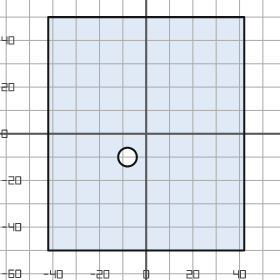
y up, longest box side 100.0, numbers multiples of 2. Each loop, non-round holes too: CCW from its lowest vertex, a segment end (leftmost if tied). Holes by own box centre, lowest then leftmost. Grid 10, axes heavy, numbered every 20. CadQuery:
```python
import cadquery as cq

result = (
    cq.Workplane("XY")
    .moveTo(-42.0, -50.0)
    .lineTo(42.0, -50.0)
    .lineTo(42.0, 50.0)
    .lineTo(-42.0, 50.0)
    .close()
    .moveTo(-8.0, -10.0)
    .circle(4.0)
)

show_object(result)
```